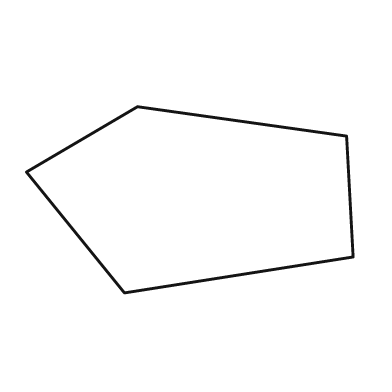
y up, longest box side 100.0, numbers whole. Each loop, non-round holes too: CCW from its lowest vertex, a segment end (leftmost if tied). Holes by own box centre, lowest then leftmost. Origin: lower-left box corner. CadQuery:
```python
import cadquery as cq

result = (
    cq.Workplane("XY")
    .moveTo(30.0, 0.0)
    .lineTo(100.0, 11.0)
    .lineTo(98.0, 48.0)
    .lineTo(34.0, 57.0)
    .lineTo(0.0, 37.0)
    .close()
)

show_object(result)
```